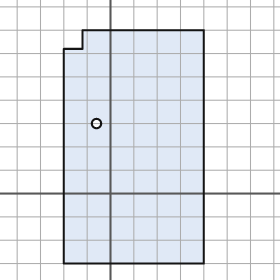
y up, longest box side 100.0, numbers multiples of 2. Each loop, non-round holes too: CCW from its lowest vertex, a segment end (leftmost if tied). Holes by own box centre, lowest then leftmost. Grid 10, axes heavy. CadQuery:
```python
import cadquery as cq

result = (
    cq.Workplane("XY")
    .moveTo(-20.0, -30.0)
    .lineTo(40.0, -30.0)
    .lineTo(40.0, 70.0)
    .lineTo(-12.0, 70.0)
    .lineTo(-12.0, 62.0)
    .lineTo(-20.0, 62.0)
    .close()
    .moveTo(-6.0, 30.0)
    .circle(2.0)
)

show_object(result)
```